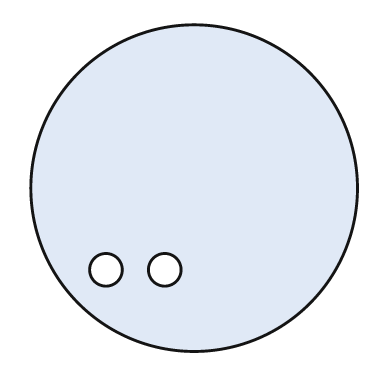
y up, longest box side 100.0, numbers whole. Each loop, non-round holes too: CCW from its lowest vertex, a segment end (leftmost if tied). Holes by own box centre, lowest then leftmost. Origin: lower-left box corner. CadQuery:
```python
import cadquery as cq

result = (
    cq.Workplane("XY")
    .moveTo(50.0, 50.0)
    .circle(50.0)
    .moveTo(23.0, 25.0)
    .circle(5.0)
    .moveTo(41.0, 25.0)
    .circle(5.0)
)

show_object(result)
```